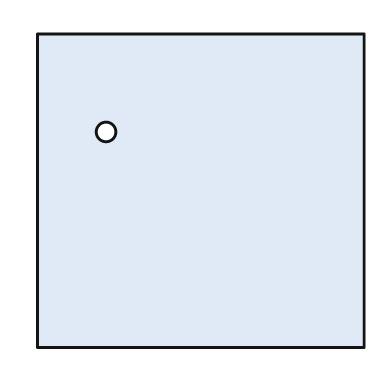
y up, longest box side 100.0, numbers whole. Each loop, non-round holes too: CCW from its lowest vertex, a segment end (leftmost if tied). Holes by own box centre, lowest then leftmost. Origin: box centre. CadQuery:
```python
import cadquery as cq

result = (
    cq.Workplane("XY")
    .moveTo(-50.0, -48.0)
    .lineTo(50.0, -48.0)
    .lineTo(50.0, 48.0)
    .lineTo(-50.0, 48.0)
    .close()
    .moveTo(-29.0, 18.0)
    .circle(3.0)
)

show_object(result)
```